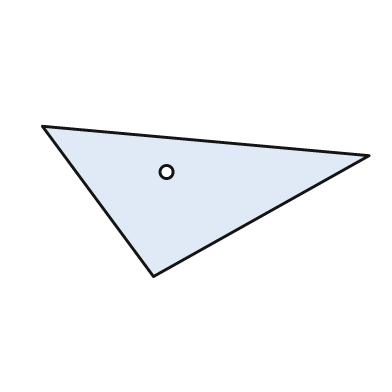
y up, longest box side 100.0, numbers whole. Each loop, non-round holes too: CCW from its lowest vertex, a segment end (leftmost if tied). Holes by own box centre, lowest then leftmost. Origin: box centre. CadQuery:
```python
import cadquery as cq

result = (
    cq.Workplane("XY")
    .moveTo(-16.0, -23.0)
    .lineTo(50.0, 14.0)
    .lineTo(-50.0, 23.0)
    .close()
    .moveTo(-12.0, 9.0)
    .circle(2.0)
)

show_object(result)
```